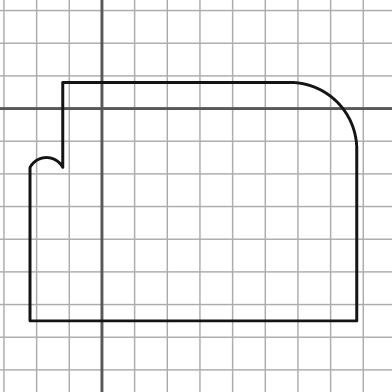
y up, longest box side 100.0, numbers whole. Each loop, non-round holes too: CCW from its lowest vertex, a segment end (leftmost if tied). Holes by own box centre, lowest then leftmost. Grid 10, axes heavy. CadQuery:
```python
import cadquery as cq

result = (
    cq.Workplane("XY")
    .moveTo(-22.0, -65.0)
    .lineTo(78.0, -65.0)
    .lineTo(78.0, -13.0)
    .threePointArc((72.0, 2.0), (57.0, 8.0))
    .lineTo(-12.0, 8.0)
    .lineTo(-12.0, -18.0)
    .threePointArc((-17.0, -15.0), (-22.0, -18.0))
    .close()
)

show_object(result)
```